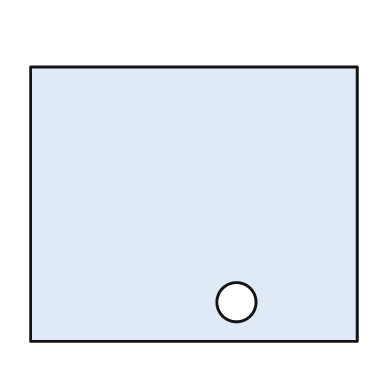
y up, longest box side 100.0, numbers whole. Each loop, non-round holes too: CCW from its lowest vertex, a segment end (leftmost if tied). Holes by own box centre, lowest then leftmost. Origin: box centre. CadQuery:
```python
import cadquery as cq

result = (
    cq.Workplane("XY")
    .moveTo(-50.0, -42.0)
    .lineTo(50.0, -42.0)
    .lineTo(50.0, 42.0)
    .lineTo(-50.0, 42.0)
    .close()
    .moveTo(13.0, -30.0)
    .circle(6.0)
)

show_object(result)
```